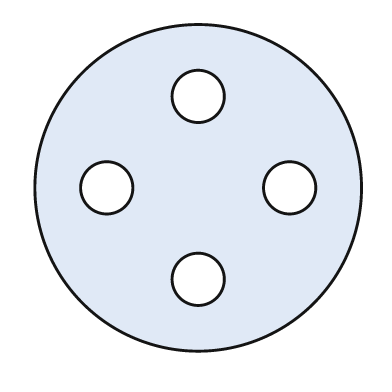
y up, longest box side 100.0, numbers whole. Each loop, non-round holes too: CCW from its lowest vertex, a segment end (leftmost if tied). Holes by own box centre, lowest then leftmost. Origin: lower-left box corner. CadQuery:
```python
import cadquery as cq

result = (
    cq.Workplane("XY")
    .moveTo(50.0, 50.0)
    .circle(50.0)
    .moveTo(50.0, 22.0)
    .circle(8.0)
    .moveTo(22.0, 50.0)
    .circle(8.0)
    .moveTo(78.0, 50.0)
    .circle(8.0)
    .moveTo(50.0, 78.0)
    .circle(8.0)
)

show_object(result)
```